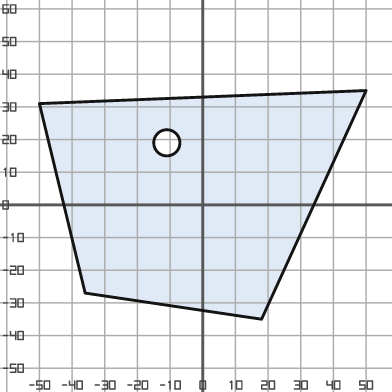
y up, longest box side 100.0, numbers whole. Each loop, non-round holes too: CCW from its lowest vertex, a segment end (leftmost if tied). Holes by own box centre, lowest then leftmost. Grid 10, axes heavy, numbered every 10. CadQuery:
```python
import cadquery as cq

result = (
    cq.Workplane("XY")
    .moveTo(18.0, -35.0)
    .lineTo(50.0, 35.0)
    .lineTo(-50.0, 31.0)
    .lineTo(-36.0, -27.0)
    .close()
    .moveTo(-11.0, 19.0)
    .circle(4.0)
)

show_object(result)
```